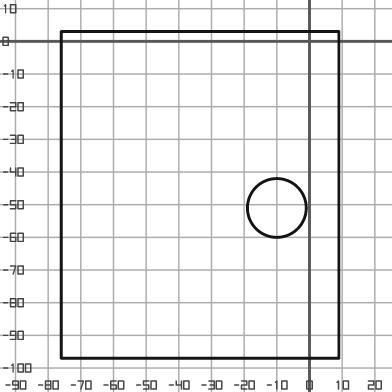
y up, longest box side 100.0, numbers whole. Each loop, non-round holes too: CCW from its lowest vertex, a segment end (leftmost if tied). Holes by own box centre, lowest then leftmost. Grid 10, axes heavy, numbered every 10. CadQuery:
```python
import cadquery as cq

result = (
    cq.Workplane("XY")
    .moveTo(-76.0, -97.0)
    .lineTo(9.0, -97.0)
    .lineTo(9.0, 3.0)
    .lineTo(-76.0, 3.0)
    .close()
    .moveTo(-10.0, -51.0)
    .circle(9.0)
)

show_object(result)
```